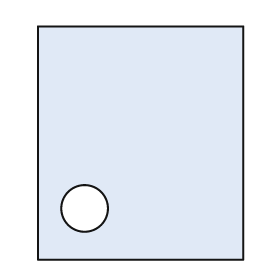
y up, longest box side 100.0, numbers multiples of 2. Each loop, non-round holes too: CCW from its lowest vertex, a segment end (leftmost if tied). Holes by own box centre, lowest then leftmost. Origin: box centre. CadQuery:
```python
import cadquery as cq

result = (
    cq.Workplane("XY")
    .moveTo(-44.0, -50.0)
    .lineTo(44.0, -50.0)
    .lineTo(44.0, 50.0)
    .lineTo(-44.0, 50.0)
    .close()
    .moveTo(-24.0, -28.0)
    .circle(10.0)
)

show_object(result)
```